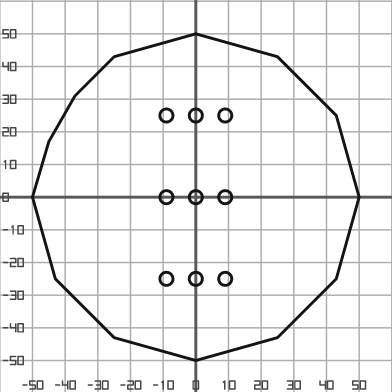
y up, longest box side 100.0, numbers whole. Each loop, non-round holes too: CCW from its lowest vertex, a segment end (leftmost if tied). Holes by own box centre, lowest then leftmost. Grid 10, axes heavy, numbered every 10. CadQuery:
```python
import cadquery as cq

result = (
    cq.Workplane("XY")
    .moveTo(0.0, -50.0)
    .lineTo(25.0, -43.0)
    .lineTo(43.0, -25.0)
    .lineTo(50.0, 0.0)
    .lineTo(43.0, 25.0)
    .lineTo(25.0, 43.0)
    .lineTo(0.0, 50.0)
    .lineTo(-25.0, 43.0)
    .lineTo(-37.0, 31.0)
    .lineTo(-45.0, 17.0)
    .lineTo(-50.0, 0.0)
    .lineTo(-43.0, -25.0)
    .lineTo(-25.0, -43.0)
    .close()
    .moveTo(-9.0, -25.0)
    .circle(2.0)
    .moveTo(0.0, -25.0)
    .circle(2.0)
    .moveTo(9.0, -25.0)
    .circle(2.0)
    .moveTo(-9.0, 0.0)
    .circle(2.0)
    .moveTo(0.0, 0.0)
    .circle(2.0)
    .moveTo(9.0, 0.0)
    .circle(2.0)
    .moveTo(-9.0, 25.0)
    .circle(2.0)
    .moveTo(0.0, 25.0)
    .circle(2.0)
    .moveTo(9.0, 25.0)
    .circle(2.0)
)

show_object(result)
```